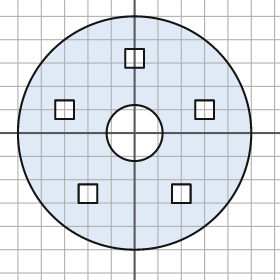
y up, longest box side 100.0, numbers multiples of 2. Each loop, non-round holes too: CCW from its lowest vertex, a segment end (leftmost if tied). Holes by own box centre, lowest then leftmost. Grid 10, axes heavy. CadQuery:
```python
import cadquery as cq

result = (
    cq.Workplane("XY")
    .moveTo(0.0, 0.0)
    .circle(50.0)
    .moveTo(-24.0, -30.0)
    .lineTo(-16.0, -30.0)
    .lineTo(-16.0, -22.0)
    .lineTo(-24.0, -22.0)
    .close()
    .moveTo(16.0, -30.0)
    .lineTo(24.0, -30.0)
    .lineTo(24.0, -22.0)
    .lineTo(16.0, -22.0)
    .close()
    .moveTo(0.0, 0.0)
    .circle(12.0)
    .moveTo(-34.0, 6.0)
    .lineTo(-26.0, 6.0)
    .lineTo(-26.0, 14.0)
    .lineTo(-34.0, 14.0)
    .close()
    .moveTo(26.0, 6.0)
    .lineTo(34.0, 6.0)
    .lineTo(34.0, 14.0)
    .lineTo(26.0, 14.0)
    .close()
    .moveTo(-4.0, 28.0)
    .lineTo(4.0, 28.0)
    .lineTo(4.0, 36.0)
    .lineTo(-4.0, 36.0)
    .close()
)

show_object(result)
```